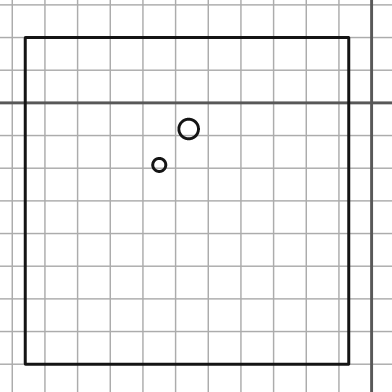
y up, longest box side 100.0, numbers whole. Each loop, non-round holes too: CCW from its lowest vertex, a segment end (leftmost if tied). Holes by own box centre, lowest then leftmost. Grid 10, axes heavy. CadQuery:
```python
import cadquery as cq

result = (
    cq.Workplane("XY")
    .moveTo(-106.0, -80.0)
    .lineTo(-7.0, -80.0)
    .lineTo(-7.0, 20.0)
    .lineTo(-106.0, 20.0)
    .close()
    .moveTo(-65.0, -19.0)
    .circle(2.0)
    .moveTo(-56.0, -8.0)
    .circle(3.0)
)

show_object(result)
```